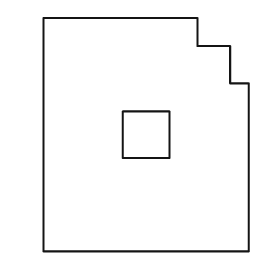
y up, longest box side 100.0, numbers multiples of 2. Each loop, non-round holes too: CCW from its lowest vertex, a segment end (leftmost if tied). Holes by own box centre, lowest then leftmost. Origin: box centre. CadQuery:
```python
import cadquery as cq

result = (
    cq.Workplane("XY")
    .moveTo(-44.0, -50.0)
    .lineTo(44.0, -50.0)
    .lineTo(44.0, 22.0)
    .lineTo(36.0, 22.0)
    .lineTo(36.0, 38.0)
    .lineTo(22.0, 38.0)
    .lineTo(22.0, 50.0)
    .lineTo(-44.0, 50.0)
    .close()
    .moveTo(-10.0, -10.0)
    .lineTo(10.0, -10.0)
    .lineTo(10.0, 10.0)
    .lineTo(-10.0, 10.0)
    .close()
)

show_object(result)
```